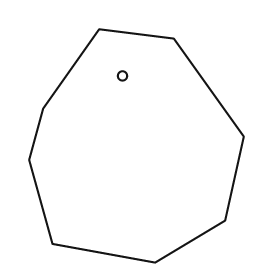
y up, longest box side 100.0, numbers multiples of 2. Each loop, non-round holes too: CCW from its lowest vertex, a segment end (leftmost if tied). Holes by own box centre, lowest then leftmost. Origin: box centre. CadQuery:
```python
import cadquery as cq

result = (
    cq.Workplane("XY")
    .moveTo(8.0, -50.0)
    .lineTo(38.0, -32.0)
    .lineTo(46.0, 4.0)
    .lineTo(16.0, 46.0)
    .lineTo(-16.0, 50.0)
    .lineTo(-40.0, 16.0)
    .lineTo(-46.0, -6.0)
    .lineTo(-36.0, -42.0)
    .close()
    .moveTo(-6.0, 30.0)
    .circle(2.0)
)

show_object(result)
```